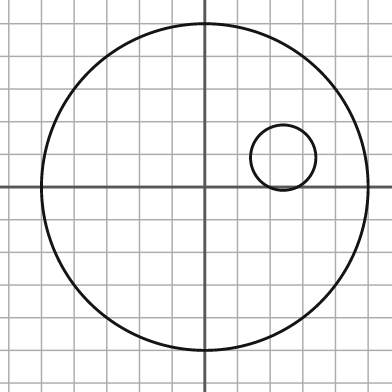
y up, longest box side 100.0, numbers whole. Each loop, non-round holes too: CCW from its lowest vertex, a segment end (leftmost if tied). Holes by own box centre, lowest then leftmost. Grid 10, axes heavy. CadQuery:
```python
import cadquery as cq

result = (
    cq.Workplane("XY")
    .moveTo(0.0, 0.0)
    .circle(50.0)
    .moveTo(24.0, 9.0)
    .circle(10.0)
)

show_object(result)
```